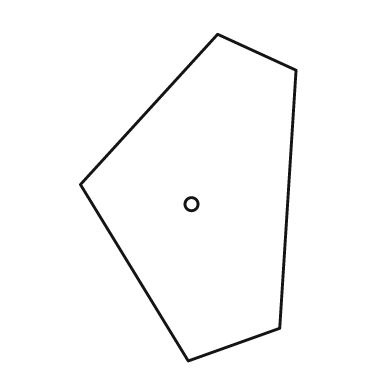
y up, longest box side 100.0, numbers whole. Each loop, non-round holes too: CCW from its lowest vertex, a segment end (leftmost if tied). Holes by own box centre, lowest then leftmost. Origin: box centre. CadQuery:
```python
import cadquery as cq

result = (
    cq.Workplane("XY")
    .moveTo(0.0, -50.0)
    .lineTo(28.0, -40.0)
    .lineTo(33.0, 39.0)
    .lineTo(9.0, 50.0)
    .lineTo(-33.0, 4.0)
    .close()
    .moveTo(1.0, -2.0)
    .circle(2.0)
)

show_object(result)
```